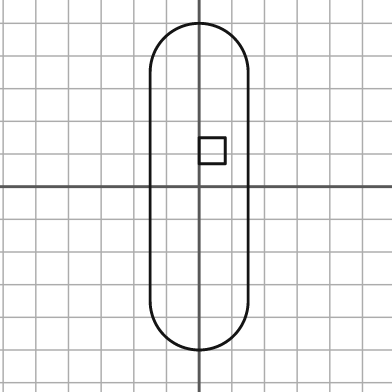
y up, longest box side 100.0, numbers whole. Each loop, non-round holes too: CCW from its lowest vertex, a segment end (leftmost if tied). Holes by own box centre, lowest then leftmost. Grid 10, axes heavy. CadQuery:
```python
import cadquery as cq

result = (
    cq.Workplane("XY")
    .moveTo(-15.0, -35.0)
    .threePointArc((0.0, -50.0), (15.0, -35.0))
    .lineTo(15.0, 35.0)
    .threePointArc((0.0, 50.0), (-15.0, 35.0))
    .close()
    .moveTo(0.0, 7.0)
    .lineTo(8.0, 7.0)
    .lineTo(8.0, 15.0)
    .lineTo(0.0, 15.0)
    .close()
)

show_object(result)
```